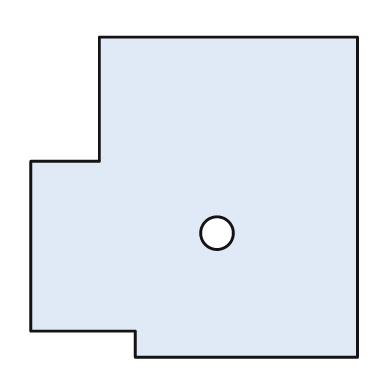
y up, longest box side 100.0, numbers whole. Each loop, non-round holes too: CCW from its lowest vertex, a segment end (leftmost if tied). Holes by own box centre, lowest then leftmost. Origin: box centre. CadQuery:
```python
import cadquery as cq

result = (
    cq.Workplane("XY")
    .moveTo(-18.0, -49.0)
    .lineTo(50.0, -49.0)
    .lineTo(50.0, 49.0)
    .lineTo(-29.0, 49.0)
    .lineTo(-29.0, 11.0)
    .lineTo(-50.0, 11.0)
    .lineTo(-50.0, -41.0)
    .lineTo(-18.0, -41.0)
    .close()
    .moveTo(7.0, -11.0)
    .circle(5.0)
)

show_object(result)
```